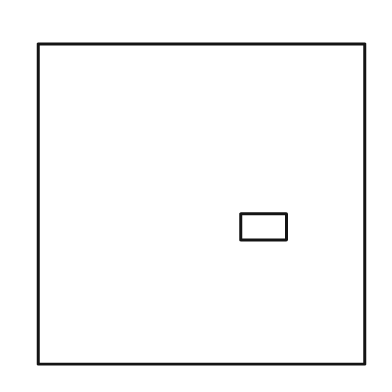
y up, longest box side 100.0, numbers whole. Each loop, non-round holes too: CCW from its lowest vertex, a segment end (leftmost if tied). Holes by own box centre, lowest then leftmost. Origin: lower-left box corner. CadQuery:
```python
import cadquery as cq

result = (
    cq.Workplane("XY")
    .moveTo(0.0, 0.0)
    .lineTo(100.0, 0.0)
    .lineTo(100.0, 98.0)
    .lineTo(0.0, 98.0)
    .close()
    .moveTo(62.0, 38.0)
    .lineTo(76.0, 38.0)
    .lineTo(76.0, 46.0)
    .lineTo(62.0, 46.0)
    .close()
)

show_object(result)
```